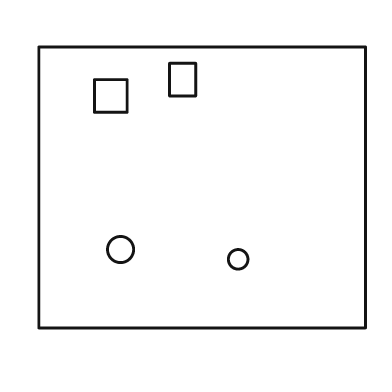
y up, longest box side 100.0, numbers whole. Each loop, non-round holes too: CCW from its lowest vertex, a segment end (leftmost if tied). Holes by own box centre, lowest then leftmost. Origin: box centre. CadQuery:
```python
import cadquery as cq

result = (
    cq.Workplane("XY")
    .moveTo(-50.0, -43.0)
    .lineTo(50.0, -43.0)
    .lineTo(50.0, 43.0)
    .lineTo(-50.0, 43.0)
    .close()
    .moveTo(11.0, -22.0)
    .circle(3.0)
    .moveTo(-25.0, -19.0)
    .circle(4.0)
    .moveTo(-33.0, 23.0)
    .lineTo(-23.0, 23.0)
    .lineTo(-23.0, 33.0)
    .lineTo(-33.0, 33.0)
    .close()
    .moveTo(-10.0, 28.0)
    .lineTo(-2.0, 28.0)
    .lineTo(-2.0, 38.0)
    .lineTo(-10.0, 38.0)
    .close()
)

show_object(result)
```